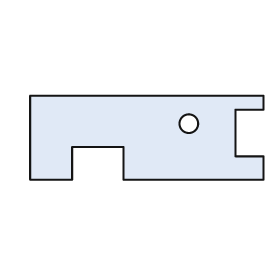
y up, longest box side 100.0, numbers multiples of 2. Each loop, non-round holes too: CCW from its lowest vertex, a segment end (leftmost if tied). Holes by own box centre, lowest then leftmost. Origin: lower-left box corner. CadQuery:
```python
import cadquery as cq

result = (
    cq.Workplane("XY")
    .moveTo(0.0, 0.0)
    .lineTo(18.0, 0.0)
    .lineTo(18.0, 14.0)
    .lineTo(40.0, 14.0)
    .lineTo(40.0, 0.0)
    .lineTo(100.0, 0.0)
    .lineTo(100.0, 10.0)
    .lineTo(88.0, 10.0)
    .lineTo(88.0, 30.0)
    .lineTo(100.0, 30.0)
    .lineTo(100.0, 36.0)
    .lineTo(0.0, 36.0)
    .close()
    .moveTo(68.0, 24.0)
    .circle(4.0)
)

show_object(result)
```